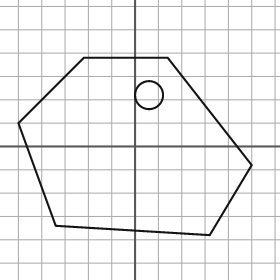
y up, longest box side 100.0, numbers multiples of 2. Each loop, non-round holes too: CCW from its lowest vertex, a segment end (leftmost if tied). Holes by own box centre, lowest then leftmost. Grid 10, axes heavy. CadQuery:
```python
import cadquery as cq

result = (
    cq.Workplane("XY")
    .moveTo(32.0, -38.0)
    .lineTo(50.0, -8.0)
    .lineTo(14.0, 38.0)
    .lineTo(-22.0, 38.0)
    .lineTo(-50.0, 10.0)
    .lineTo(-34.0, -34.0)
    .close()
    .moveTo(6.0, 22.0)
    .circle(6.0)
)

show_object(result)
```